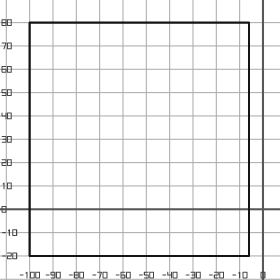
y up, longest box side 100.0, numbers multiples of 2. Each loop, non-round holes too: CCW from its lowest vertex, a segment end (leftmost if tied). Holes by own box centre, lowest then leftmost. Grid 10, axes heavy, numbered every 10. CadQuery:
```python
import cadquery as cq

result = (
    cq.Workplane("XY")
    .moveTo(-100.0, -20.0)
    .lineTo(-6.0, -20.0)
    .lineTo(-6.0, 80.0)
    .lineTo(-100.0, 80.0)
    .close()
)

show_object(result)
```